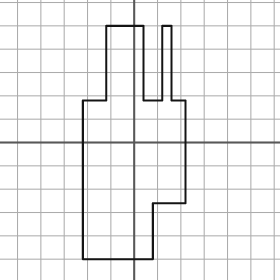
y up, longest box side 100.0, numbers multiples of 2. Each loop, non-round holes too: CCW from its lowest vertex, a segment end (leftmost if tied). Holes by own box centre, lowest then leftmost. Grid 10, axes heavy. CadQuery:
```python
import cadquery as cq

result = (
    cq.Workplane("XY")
    .moveTo(-22.0, -50.0)
    .lineTo(8.0, -50.0)
    .lineTo(8.0, -26.0)
    .lineTo(22.0, -26.0)
    .lineTo(22.0, 18.0)
    .lineTo(16.0, 18.0)
    .lineTo(16.0, 50.0)
    .lineTo(12.0, 50.0)
    .lineTo(12.0, 18.0)
    .lineTo(4.0, 18.0)
    .lineTo(4.0, 50.0)
    .lineTo(-12.0, 50.0)
    .lineTo(-12.0, 18.0)
    .lineTo(-22.0, 18.0)
    .close()
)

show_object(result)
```